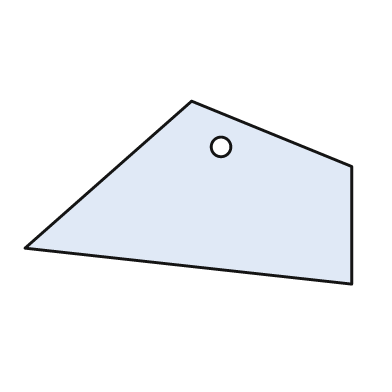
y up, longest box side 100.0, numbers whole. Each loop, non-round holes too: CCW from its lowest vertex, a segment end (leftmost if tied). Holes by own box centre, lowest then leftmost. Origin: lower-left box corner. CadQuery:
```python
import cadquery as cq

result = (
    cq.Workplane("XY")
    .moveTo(100.0, 0.0)
    .lineTo(100.0, 36.0)
    .lineTo(51.0, 56.0)
    .lineTo(0.0, 11.0)
    .close()
    .moveTo(60.0, 42.0)
    .circle(3.0)
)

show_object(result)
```